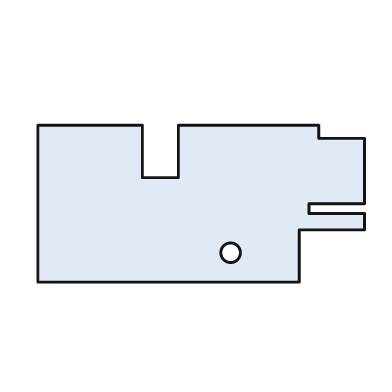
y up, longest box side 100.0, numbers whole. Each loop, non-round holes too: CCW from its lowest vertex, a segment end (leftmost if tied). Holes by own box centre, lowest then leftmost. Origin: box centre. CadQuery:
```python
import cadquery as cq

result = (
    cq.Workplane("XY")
    .moveTo(-50.0, -24.0)
    .lineTo(30.0, -24.0)
    .lineTo(30.0, -8.0)
    .lineTo(50.0, -8.0)
    .lineTo(50.0, -3.0)
    .lineTo(33.0, -3.0)
    .lineTo(33.0, 0.0)
    .lineTo(50.0, 0.0)
    .lineTo(50.0, 20.0)
    .lineTo(36.0, 20.0)
    .lineTo(36.0, 24.0)
    .lineTo(-7.0, 24.0)
    .lineTo(-7.0, 8.0)
    .lineTo(-18.0, 8.0)
    .lineTo(-18.0, 24.0)
    .lineTo(-50.0, 24.0)
    .close()
    .moveTo(9.0, -15.0)
    .circle(3.0)
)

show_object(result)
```